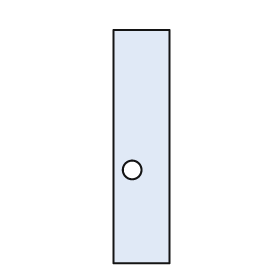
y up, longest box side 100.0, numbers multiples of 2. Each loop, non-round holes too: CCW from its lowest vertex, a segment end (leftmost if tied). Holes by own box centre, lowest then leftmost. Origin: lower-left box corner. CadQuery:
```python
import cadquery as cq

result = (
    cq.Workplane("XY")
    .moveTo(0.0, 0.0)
    .lineTo(24.0, 0.0)
    .lineTo(24.0, 100.0)
    .lineTo(0.0, 100.0)
    .close()
    .moveTo(8.0, 40.0)
    .circle(4.0)
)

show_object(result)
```